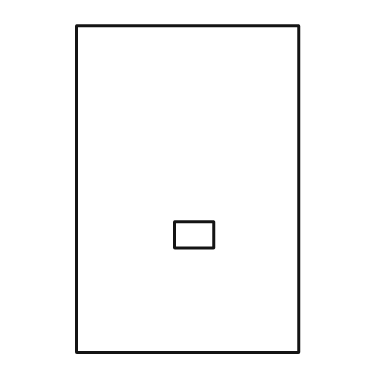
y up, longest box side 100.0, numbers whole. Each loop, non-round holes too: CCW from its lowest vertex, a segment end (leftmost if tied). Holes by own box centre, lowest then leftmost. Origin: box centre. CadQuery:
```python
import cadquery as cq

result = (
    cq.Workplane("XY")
    .moveTo(-34.0, -50.0)
    .lineTo(34.0, -50.0)
    .lineTo(34.0, 50.0)
    .lineTo(-34.0, 50.0)
    .close()
    .moveTo(-4.0, -18.0)
    .lineTo(8.0, -18.0)
    .lineTo(8.0, -10.0)
    .lineTo(-4.0, -10.0)
    .close()
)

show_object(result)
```